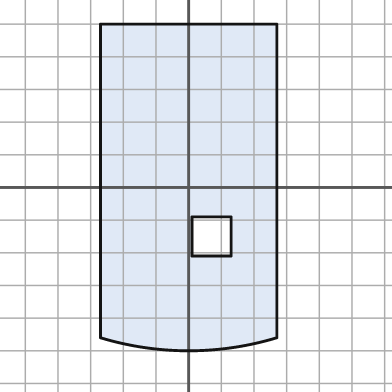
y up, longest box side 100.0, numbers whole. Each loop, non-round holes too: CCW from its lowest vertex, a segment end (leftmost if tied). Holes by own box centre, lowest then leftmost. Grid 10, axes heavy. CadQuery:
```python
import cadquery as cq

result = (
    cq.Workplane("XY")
    .moveTo(-27.0, -46.0)
    .threePointArc((0.0, -50.0), (27.0, -46.0))
    .lineTo(27.0, 50.0)
    .lineTo(-27.0, 50.0)
    .close()
    .moveTo(1.0, -21.0)
    .lineTo(13.0, -21.0)
    .lineTo(13.0, -9.0)
    .lineTo(1.0, -9.0)
    .close()
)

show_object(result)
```